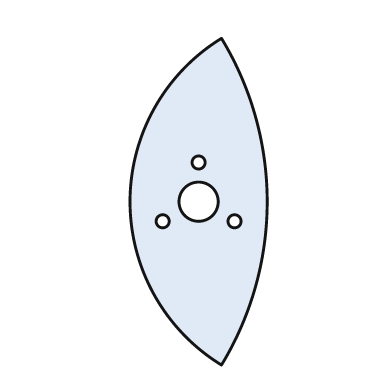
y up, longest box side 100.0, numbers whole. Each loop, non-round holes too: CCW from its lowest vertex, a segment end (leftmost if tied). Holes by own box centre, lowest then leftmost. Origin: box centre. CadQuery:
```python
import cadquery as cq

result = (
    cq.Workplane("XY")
    .moveTo(7.0, -50.0)
    .threePointArc((21.0, 0.0), (7.0, 50.0))
    .threePointArc((-21.0, 0.0), (7.0, -50.0))
    .close()
    .moveTo(-11.0, -6.0)
    .circle(2.0)
    .moveTo(11.0, -6.0)
    .circle(2.0)
    .moveTo(0.0, 0.0)
    .circle(6.0)
    .moveTo(0.0, 12.0)
    .circle(2.0)
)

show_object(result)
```